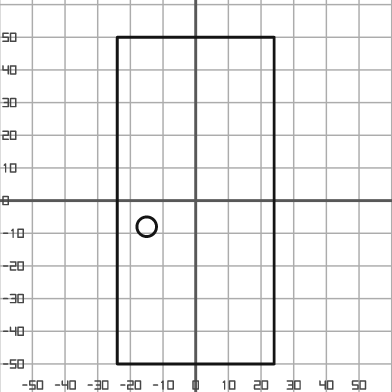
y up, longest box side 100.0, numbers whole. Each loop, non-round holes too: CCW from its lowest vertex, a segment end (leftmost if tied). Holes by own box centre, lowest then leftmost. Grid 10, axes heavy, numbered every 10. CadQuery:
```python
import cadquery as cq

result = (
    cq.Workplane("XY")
    .moveTo(-24.0, -50.0)
    .lineTo(24.0, -50.0)
    .lineTo(24.0, 50.0)
    .lineTo(-24.0, 50.0)
    .close()
    .moveTo(-15.0, -8.0)
    .circle(3.0)
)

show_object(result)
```